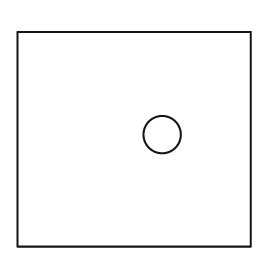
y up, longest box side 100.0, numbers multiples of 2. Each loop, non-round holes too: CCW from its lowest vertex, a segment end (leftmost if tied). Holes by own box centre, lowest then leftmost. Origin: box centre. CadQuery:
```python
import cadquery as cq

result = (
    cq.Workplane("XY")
    .moveTo(-50.0, -46.0)
    .lineTo(50.0, -46.0)
    .lineTo(50.0, 46.0)
    .lineTo(-50.0, 46.0)
    .close()
    .moveTo(12.0, 2.0)
    .circle(8.0)
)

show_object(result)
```